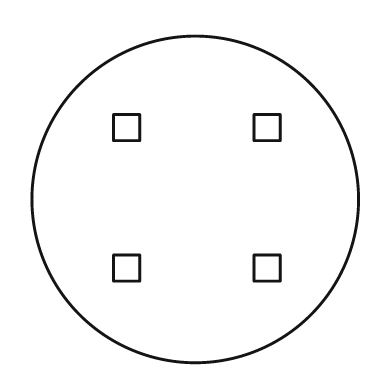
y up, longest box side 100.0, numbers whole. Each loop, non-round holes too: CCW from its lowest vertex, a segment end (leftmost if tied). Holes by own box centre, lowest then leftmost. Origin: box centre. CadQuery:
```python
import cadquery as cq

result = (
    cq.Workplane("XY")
    .moveTo(0.0, 0.0)
    .circle(50.0)
    .moveTo(-25.0, -25.0)
    .lineTo(-17.0, -25.0)
    .lineTo(-17.0, -17.0)
    .lineTo(-25.0, -17.0)
    .close()
    .moveTo(18.0, -25.0)
    .lineTo(26.0, -25.0)
    .lineTo(26.0, -17.0)
    .lineTo(18.0, -17.0)
    .close()
    .moveTo(-25.0, 18.0)
    .lineTo(-17.0, 18.0)
    .lineTo(-17.0, 26.0)
    .lineTo(-25.0, 26.0)
    .close()
    .moveTo(18.0, 18.0)
    .lineTo(26.0, 18.0)
    .lineTo(26.0, 26.0)
    .lineTo(18.0, 26.0)
    .close()
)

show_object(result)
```